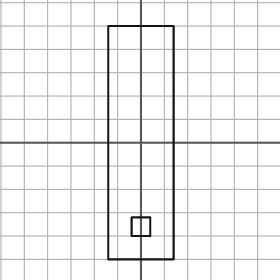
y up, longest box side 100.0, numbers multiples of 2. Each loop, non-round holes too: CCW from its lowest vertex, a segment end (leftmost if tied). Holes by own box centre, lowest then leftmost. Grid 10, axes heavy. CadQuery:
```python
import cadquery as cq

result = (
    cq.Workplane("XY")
    .moveTo(-14.0, -50.0)
    .lineTo(14.0, -50.0)
    .lineTo(14.0, 50.0)
    .lineTo(-14.0, 50.0)
    .close()
    .moveTo(-4.0, -40.0)
    .lineTo(4.0, -40.0)
    .lineTo(4.0, -32.0)
    .lineTo(-4.0, -32.0)
    .close()
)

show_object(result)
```